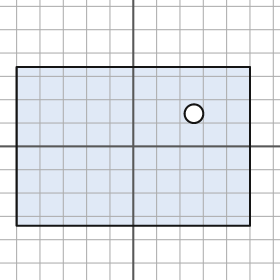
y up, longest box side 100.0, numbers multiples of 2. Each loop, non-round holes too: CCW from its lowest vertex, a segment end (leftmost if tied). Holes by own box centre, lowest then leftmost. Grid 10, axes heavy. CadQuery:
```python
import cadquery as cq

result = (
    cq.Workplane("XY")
    .moveTo(-50.0, -34.0)
    .lineTo(50.0, -34.0)
    .lineTo(50.0, 34.0)
    .lineTo(-50.0, 34.0)
    .close()
    .moveTo(26.0, 14.0)
    .circle(4.0)
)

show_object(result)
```